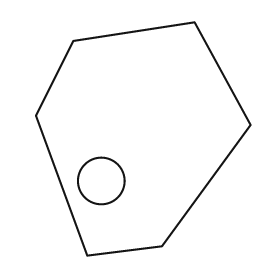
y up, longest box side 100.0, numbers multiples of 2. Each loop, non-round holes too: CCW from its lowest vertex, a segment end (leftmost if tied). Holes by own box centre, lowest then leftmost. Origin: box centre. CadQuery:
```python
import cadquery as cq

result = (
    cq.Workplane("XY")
    .moveTo(-24.0, -50.0)
    .lineTo(8.0, -46.0)
    .lineTo(46.0, 6.0)
    .lineTo(22.0, 50.0)
    .lineTo(-30.0, 42.0)
    .lineTo(-46.0, 10.0)
    .close()
    .moveTo(-18.0, -18.0)
    .circle(10.0)
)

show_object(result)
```